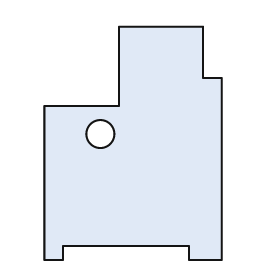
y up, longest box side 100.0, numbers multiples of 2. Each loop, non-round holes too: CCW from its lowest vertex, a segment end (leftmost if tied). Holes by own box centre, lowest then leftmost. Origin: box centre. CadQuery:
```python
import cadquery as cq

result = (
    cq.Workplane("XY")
    .moveTo(-38.0, -50.0)
    .lineTo(-30.0, -50.0)
    .lineTo(-30.0, -44.0)
    .lineTo(24.0, -44.0)
    .lineTo(24.0, -50.0)
    .lineTo(38.0, -50.0)
    .lineTo(38.0, 28.0)
    .lineTo(30.0, 28.0)
    .lineTo(30.0, 50.0)
    .lineTo(-6.0, 50.0)
    .lineTo(-6.0, 16.0)
    .lineTo(-38.0, 16.0)
    .close()
    .moveTo(-14.0, 4.0)
    .circle(6.0)
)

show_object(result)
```